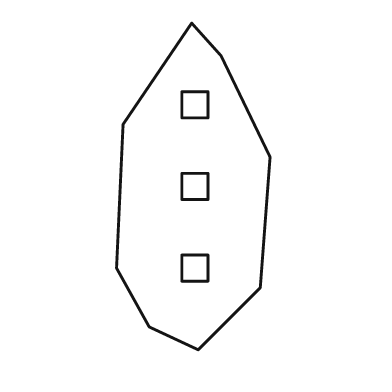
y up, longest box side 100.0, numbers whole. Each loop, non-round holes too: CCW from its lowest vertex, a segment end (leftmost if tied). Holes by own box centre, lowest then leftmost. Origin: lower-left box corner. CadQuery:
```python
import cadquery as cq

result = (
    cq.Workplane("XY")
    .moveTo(25.0, 0.0)
    .lineTo(44.0, 19.0)
    .lineTo(47.0, 59.0)
    .lineTo(32.0, 90.0)
    .lineTo(23.0, 100.0)
    .lineTo(2.0, 69.0)
    .lineTo(0.0, 25.0)
    .lineTo(10.0, 7.0)
    .close()
    .moveTo(20.0, 21.0)
    .lineTo(28.0, 21.0)
    .lineTo(28.0, 29.0)
    .lineTo(20.0, 29.0)
    .close()
    .moveTo(20.0, 46.0)
    .lineTo(28.0, 46.0)
    .lineTo(28.0, 54.0)
    .lineTo(20.0, 54.0)
    .close()
    .moveTo(20.0, 71.0)
    .lineTo(28.0, 71.0)
    .lineTo(28.0, 79.0)
    .lineTo(20.0, 79.0)
    .close()
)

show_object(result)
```